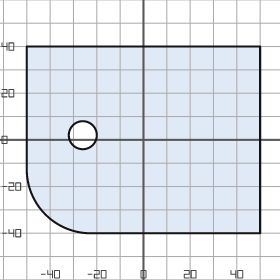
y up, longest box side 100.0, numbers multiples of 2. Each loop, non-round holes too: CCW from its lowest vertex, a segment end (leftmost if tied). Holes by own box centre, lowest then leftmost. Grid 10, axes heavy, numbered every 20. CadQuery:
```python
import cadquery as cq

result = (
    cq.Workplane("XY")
    .moveTo(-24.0, -40.0)
    .lineTo(50.0, -40.0)
    .lineTo(50.0, 40.0)
    .lineTo(-50.0, 40.0)
    .lineTo(-50.0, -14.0)
    .threePointArc((-42.0, -32.0), (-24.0, -40.0))
    .close()
    .moveTo(-26.0, 2.0)
    .circle(6.0)
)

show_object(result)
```